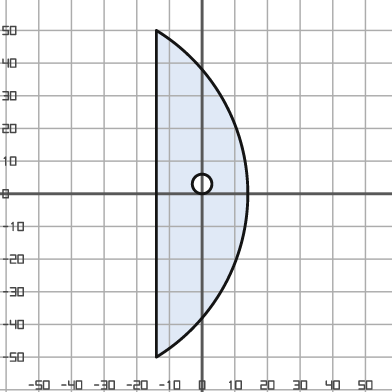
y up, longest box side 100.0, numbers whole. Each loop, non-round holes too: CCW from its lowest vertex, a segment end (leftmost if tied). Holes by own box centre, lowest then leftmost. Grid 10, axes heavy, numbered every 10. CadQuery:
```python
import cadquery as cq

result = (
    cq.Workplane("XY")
    .moveTo(-14.0, -50.0)
    .threePointArc((14.0, 0.0), (-14.0, 50.0))
    .close()
    .moveTo(0.0, 3.0)
    .circle(3.0)
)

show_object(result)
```